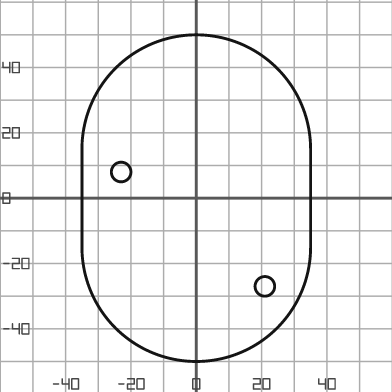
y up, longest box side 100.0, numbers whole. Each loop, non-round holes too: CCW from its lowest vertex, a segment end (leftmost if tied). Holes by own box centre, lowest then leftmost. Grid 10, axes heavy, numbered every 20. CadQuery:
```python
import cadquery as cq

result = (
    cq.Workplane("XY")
    .moveTo(-35.0, -15.0)
    .threePointArc((0.0, -50.0), (35.0, -15.0))
    .lineTo(35.0, 15.0)
    .threePointArc((0.0, 50.0), (-35.0, 15.0))
    .close()
    .moveTo(21.0, -27.0)
    .circle(3.0)
    .moveTo(-23.0, 8.0)
    .circle(3.0)
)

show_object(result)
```